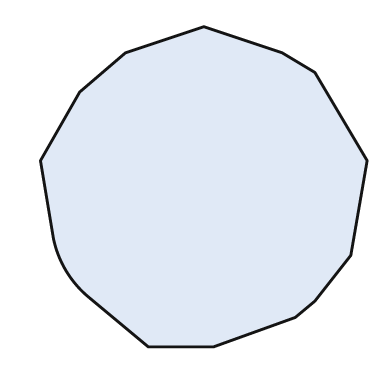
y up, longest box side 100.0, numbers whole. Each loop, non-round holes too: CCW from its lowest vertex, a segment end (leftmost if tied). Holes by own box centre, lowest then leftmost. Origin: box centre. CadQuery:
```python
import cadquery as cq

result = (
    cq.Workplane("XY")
    .moveTo(-17.0, -49.0)
    .lineTo(3.0, -49.0)
    .lineTo(28.0, -40.0)
    .lineTo(34.0, -35.0)
    .lineTo(45.0, -21.0)
    .lineTo(50.0, 8.0)
    .lineTo(34.0, 35.0)
    .lineTo(24.0, 41.0)
    .lineTo(0.0, 49.0)
    .lineTo(-24.0, 41.0)
    .lineTo(-38.0, 29.0)
    .lineTo(-50.0, 8.0)
    .lineTo(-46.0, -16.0)
    .threePointArc((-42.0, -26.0), (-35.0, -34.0))
    .close()
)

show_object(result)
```